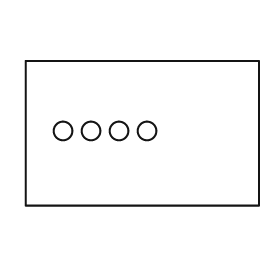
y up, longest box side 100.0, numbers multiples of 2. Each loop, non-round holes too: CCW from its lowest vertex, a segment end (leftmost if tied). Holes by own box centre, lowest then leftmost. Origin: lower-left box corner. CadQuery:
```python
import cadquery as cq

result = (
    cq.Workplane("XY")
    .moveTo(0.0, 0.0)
    .lineTo(100.0, 0.0)
    .lineTo(100.0, 62.0)
    .lineTo(0.0, 62.0)
    .close()
    .moveTo(16.0, 32.0)
    .circle(4.0)
    .moveTo(28.0, 32.0)
    .circle(4.0)
    .moveTo(40.0, 32.0)
    .circle(4.0)
    .moveTo(52.0, 32.0)
    .circle(4.0)
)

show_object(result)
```